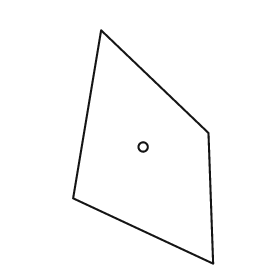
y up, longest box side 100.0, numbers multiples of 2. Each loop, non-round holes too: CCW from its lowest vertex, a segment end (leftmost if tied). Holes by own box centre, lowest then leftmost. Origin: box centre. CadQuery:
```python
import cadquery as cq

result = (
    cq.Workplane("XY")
    .moveTo(30.0, -50.0)
    .lineTo(28.0, 6.0)
    .lineTo(-18.0, 50.0)
    .lineTo(-30.0, -22.0)
    .close()
    .moveTo(0.0, 0.0)
    .circle(2.0)
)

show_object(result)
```